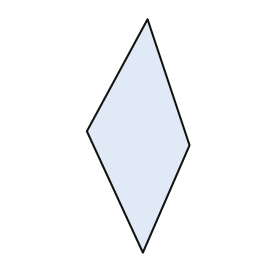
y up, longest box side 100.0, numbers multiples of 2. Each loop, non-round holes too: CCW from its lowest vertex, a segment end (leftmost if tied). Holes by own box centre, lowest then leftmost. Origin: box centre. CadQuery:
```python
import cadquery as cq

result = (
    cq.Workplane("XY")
    .moveTo(2.0, -50.0)
    .lineTo(22.0, -4.0)
    .lineTo(4.0, 50.0)
    .lineTo(-22.0, 2.0)
    .close()
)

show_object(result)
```